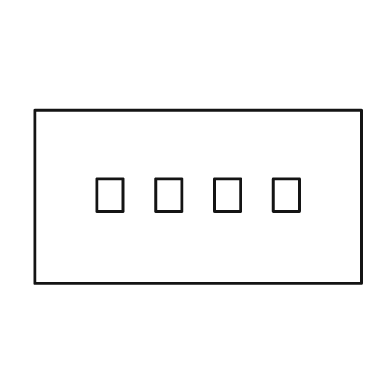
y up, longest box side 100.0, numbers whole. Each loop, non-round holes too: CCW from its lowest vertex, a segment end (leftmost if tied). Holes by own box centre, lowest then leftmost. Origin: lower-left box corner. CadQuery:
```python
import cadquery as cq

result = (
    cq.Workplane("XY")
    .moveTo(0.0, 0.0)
    .lineTo(100.0, 0.0)
    .lineTo(100.0, 53.0)
    .lineTo(0.0, 53.0)
    .close()
    .moveTo(19.0, 22.0)
    .lineTo(27.0, 22.0)
    .lineTo(27.0, 32.0)
    .lineTo(19.0, 32.0)
    .close()
    .moveTo(37.0, 22.0)
    .lineTo(45.0, 22.0)
    .lineTo(45.0, 32.0)
    .lineTo(37.0, 32.0)
    .close()
    .moveTo(55.0, 22.0)
    .lineTo(63.0, 22.0)
    .lineTo(63.0, 32.0)
    .lineTo(55.0, 32.0)
    .close()
    .moveTo(73.0, 22.0)
    .lineTo(81.0, 22.0)
    .lineTo(81.0, 32.0)
    .lineTo(73.0, 32.0)
    .close()
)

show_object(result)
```